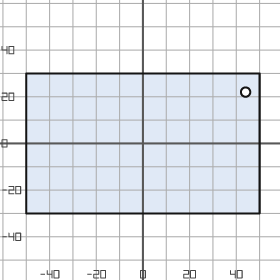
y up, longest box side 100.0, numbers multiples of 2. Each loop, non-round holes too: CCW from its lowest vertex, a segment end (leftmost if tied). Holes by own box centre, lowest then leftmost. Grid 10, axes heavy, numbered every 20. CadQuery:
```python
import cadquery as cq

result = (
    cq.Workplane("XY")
    .moveTo(-50.0, -30.0)
    .lineTo(50.0, -30.0)
    .lineTo(50.0, 30.0)
    .lineTo(-50.0, 30.0)
    .close()
    .moveTo(44.0, 22.0)
    .circle(2.0)
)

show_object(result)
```